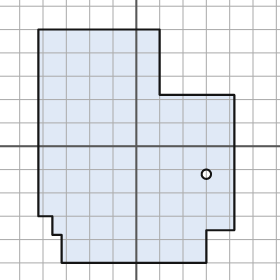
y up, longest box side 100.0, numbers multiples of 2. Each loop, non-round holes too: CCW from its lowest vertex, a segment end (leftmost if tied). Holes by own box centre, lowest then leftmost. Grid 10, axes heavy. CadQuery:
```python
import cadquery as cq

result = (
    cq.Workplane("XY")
    .moveTo(-32.0, -50.0)
    .lineTo(30.0, -50.0)
    .lineTo(30.0, -36.0)
    .lineTo(42.0, -36.0)
    .lineTo(42.0, 22.0)
    .lineTo(10.0, 22.0)
    .lineTo(10.0, 50.0)
    .lineTo(-42.0, 50.0)
    .lineTo(-42.0, -30.0)
    .lineTo(-36.0, -30.0)
    .lineTo(-36.0, -38.0)
    .lineTo(-32.0, -38.0)
    .close()
    .moveTo(30.0, -12.0)
    .circle(2.0)
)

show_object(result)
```